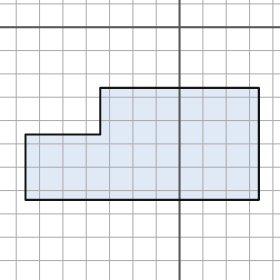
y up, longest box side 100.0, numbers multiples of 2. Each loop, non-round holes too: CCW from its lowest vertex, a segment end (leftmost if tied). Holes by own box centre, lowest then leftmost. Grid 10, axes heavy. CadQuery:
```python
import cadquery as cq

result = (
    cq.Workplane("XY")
    .moveTo(-66.0, -74.0)
    .lineTo(34.0, -74.0)
    .lineTo(34.0, -26.0)
    .lineTo(-34.0, -26.0)
    .lineTo(-34.0, -46.0)
    .lineTo(-66.0, -46.0)
    .close()
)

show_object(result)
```